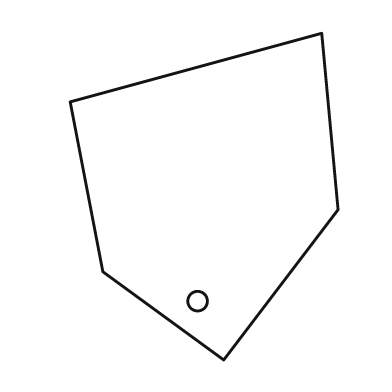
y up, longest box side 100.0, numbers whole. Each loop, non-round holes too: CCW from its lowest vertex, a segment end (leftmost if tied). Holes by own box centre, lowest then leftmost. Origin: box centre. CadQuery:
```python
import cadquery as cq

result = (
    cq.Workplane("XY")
    .moveTo(6.0, -50.0)
    .lineTo(41.0, -4.0)
    .lineTo(36.0, 50.0)
    .lineTo(-41.0, 29.0)
    .lineTo(-31.0, -23.0)
    .close()
    .moveTo(-2.0, -32.0)
    .circle(3.0)
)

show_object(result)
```